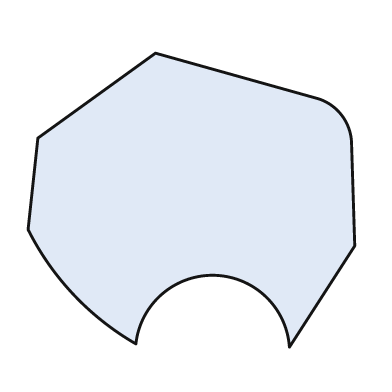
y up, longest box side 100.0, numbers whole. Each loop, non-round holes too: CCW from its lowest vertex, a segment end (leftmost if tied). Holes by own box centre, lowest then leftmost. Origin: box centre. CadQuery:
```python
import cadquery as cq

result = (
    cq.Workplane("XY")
    .moveTo(30.0, -45.0)
    .lineTo(50.0, -14.0)
    .lineTo(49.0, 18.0)
    .threePointArc((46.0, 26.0), (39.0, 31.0))
    .lineTo(-11.0, 45.0)
    .lineTo(-47.0, 19.0)
    .lineTo(-50.0, -9.0)
    .threePointArc((-36.0, -29.0), (-17.0, -44.0))
    .threePointArc((7.0, -23.0), (30.0, -45.0))
    .close()
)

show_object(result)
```